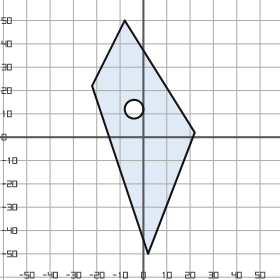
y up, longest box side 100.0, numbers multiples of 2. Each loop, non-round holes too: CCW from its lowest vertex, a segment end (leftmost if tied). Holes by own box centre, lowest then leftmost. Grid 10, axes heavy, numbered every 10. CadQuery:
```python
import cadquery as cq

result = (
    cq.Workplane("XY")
    .moveTo(2.0, -50.0)
    .lineTo(22.0, 2.0)
    .lineTo(-8.0, 50.0)
    .lineTo(-22.0, 22.0)
    .close()
    .moveTo(-4.0, 12.0)
    .circle(4.0)
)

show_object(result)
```